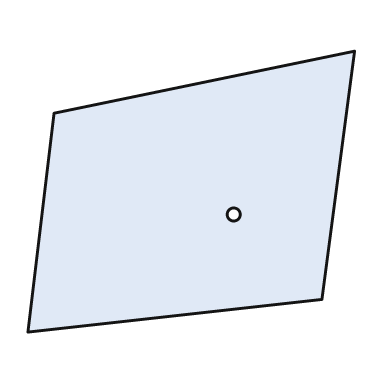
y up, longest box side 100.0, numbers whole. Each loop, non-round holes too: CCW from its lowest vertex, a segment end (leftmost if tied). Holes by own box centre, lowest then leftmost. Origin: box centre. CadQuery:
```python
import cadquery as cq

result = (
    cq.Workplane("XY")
    .moveTo(-50.0, -43.0)
    .lineTo(40.0, -33.0)
    .lineTo(50.0, 43.0)
    .lineTo(-42.0, 24.0)
    .close()
    .moveTo(13.0, -7.0)
    .circle(2.0)
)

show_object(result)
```